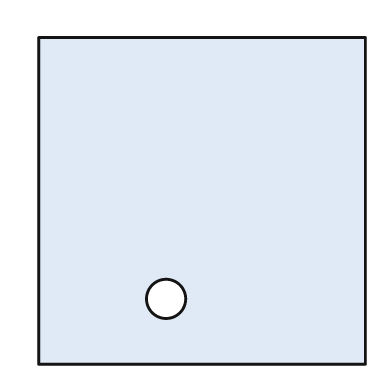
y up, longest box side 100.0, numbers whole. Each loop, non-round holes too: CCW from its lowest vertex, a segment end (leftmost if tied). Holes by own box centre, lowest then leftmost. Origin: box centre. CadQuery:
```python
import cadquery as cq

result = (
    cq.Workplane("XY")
    .moveTo(-50.0, -50.0)
    .lineTo(50.0, -50.0)
    .lineTo(50.0, 50.0)
    .lineTo(-50.0, 50.0)
    .close()
    .moveTo(-11.0, -30.0)
    .circle(6.0)
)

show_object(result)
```